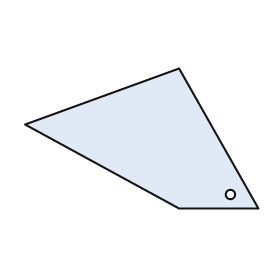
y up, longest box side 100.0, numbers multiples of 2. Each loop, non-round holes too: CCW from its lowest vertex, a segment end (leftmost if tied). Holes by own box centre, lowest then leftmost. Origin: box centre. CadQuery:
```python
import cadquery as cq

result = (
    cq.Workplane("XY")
    .moveTo(16.0, -30.0)
    .lineTo(50.0, -30.0)
    .lineTo(16.0, 30.0)
    .lineTo(-50.0, 6.0)
    .close()
    .moveTo(38.0, -24.0)
    .circle(2.0)
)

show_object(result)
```